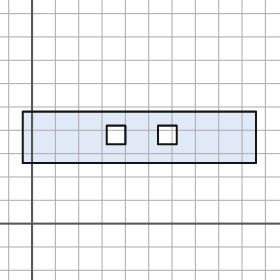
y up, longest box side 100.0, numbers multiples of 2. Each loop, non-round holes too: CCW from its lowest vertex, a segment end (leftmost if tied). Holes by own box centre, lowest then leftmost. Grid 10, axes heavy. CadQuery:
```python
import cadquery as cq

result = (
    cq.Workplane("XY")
    .moveTo(-4.0, 26.0)
    .lineTo(96.0, 26.0)
    .lineTo(96.0, 48.0)
    .lineTo(-4.0, 48.0)
    .close()
    .moveTo(32.0, 34.0)
    .lineTo(40.0, 34.0)
    .lineTo(40.0, 42.0)
    .lineTo(32.0, 42.0)
    .close()
    .moveTo(54.0, 34.0)
    .lineTo(62.0, 34.0)
    .lineTo(62.0, 42.0)
    .lineTo(54.0, 42.0)
    .close()
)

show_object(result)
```